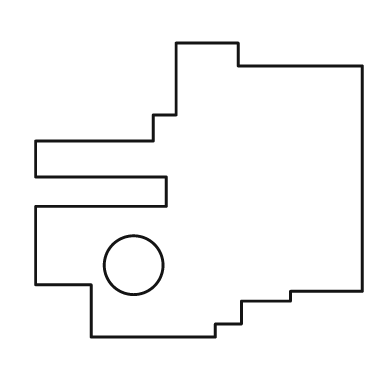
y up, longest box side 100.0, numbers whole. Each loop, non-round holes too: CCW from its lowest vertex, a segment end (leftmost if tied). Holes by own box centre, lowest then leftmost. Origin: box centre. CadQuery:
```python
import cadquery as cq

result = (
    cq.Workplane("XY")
    .moveTo(-33.0, -45.0)
    .lineTo(5.0, -45.0)
    .lineTo(5.0, -41.0)
    .lineTo(13.0, -41.0)
    .lineTo(13.0, -34.0)
    .lineTo(28.0, -34.0)
    .lineTo(28.0, -31.0)
    .lineTo(50.0, -31.0)
    .lineTo(50.0, 38.0)
    .lineTo(12.0, 38.0)
    .lineTo(12.0, 45.0)
    .lineTo(-7.0, 45.0)
    .lineTo(-7.0, 23.0)
    .lineTo(-14.0, 23.0)
    .lineTo(-14.0, 15.0)
    .lineTo(-50.0, 15.0)
    .lineTo(-50.0, 4.0)
    .lineTo(-10.0, 4.0)
    .lineTo(-10.0, -5.0)
    .lineTo(-50.0, -5.0)
    .lineTo(-50.0, -29.0)
    .lineTo(-33.0, -29.0)
    .close()
    .moveTo(-20.0, -23.0)
    .circle(9.0)
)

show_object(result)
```